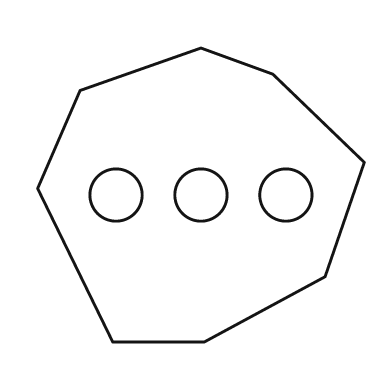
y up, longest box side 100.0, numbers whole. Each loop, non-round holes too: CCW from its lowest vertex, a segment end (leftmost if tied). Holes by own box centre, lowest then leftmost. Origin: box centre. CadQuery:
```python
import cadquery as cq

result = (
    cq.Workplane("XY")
    .moveTo(-27.0, -45.0)
    .lineTo(1.0, -45.0)
    .lineTo(38.0, -25.0)
    .lineTo(50.0, 10.0)
    .lineTo(22.0, 37.0)
    .lineTo(0.0, 45.0)
    .lineTo(-37.0, 32.0)
    .lineTo(-50.0, 2.0)
    .close()
    .moveTo(-26.0, 0.0)
    .circle(8.0)
    .moveTo(0.0, 0.0)
    .circle(8.0)
    .moveTo(26.0, 0.0)
    .circle(8.0)
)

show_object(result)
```